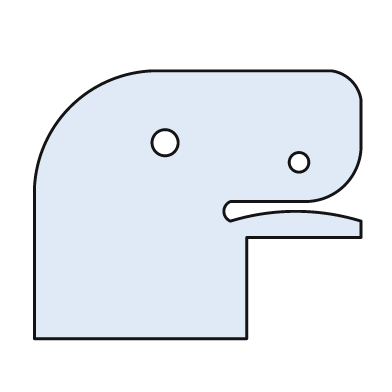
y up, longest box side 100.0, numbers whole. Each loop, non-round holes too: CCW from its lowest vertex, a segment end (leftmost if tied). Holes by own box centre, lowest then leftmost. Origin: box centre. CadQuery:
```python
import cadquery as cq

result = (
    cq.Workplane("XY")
    .moveTo(-50.0, -41.0)
    .lineTo(15.0, -41.0)
    .lineTo(15.0, -10.0)
    .lineTo(50.0, -10.0)
    .lineTo(50.0, -5.0)
    .threePointArc((30.0, -2.0), (10.0, -5.0))
    .threePointArc((8.0, -2.0), (10.0, 1.0))
    .lineTo(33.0, 1.0)
    .threePointArc((45.0, 6.0), (50.0, 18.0))
    .lineTo(50.0, 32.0)
    .threePointArc((47.0, 38.0), (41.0, 41.0))
    .lineTo(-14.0, 41.0)
    .threePointArc((-39.0, 30.0), (-50.0, 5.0))
    .close()
    .moveTo(31.0, 13.0)
    .circle(3.0)
    .moveTo(-10.0, 19.0)
    .circle(4.0)
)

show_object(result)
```